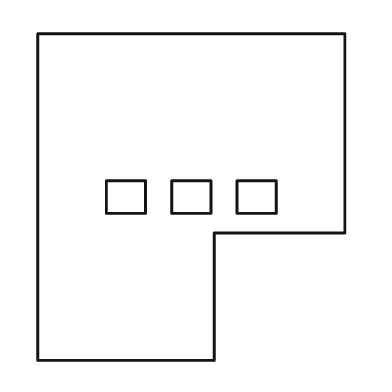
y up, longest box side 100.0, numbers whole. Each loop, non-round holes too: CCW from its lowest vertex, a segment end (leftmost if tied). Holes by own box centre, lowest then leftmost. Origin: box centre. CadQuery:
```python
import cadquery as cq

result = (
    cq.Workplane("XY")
    .moveTo(-47.0, -50.0)
    .lineTo(7.0, -50.0)
    .lineTo(7.0, -11.0)
    .lineTo(47.0, -11.0)
    .lineTo(47.0, 50.0)
    .lineTo(-47.0, 50.0)
    .close()
    .moveTo(-26.0, -5.0)
    .lineTo(-14.0, -5.0)
    .lineTo(-14.0, 5.0)
    .lineTo(-26.0, 5.0)
    .close()
    .moveTo(-6.0, -5.0)
    .lineTo(6.0, -5.0)
    .lineTo(6.0, 5.0)
    .lineTo(-6.0, 5.0)
    .close()
    .moveTo(14.0, -5.0)
    .lineTo(26.0, -5.0)
    .lineTo(26.0, 5.0)
    .lineTo(14.0, 5.0)
    .close()
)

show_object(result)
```